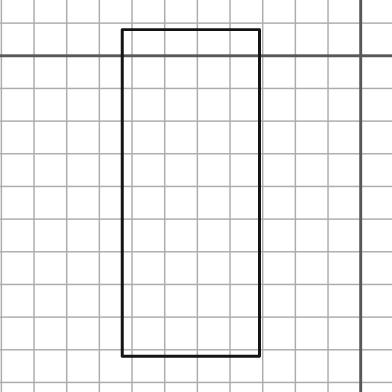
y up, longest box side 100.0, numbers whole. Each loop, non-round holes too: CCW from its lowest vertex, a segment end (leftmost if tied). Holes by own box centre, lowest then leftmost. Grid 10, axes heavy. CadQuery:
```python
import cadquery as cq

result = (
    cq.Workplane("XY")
    .moveTo(-73.0, -92.0)
    .lineTo(-31.0, -92.0)
    .lineTo(-31.0, 8.0)
    .lineTo(-73.0, 8.0)
    .close()
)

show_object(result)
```